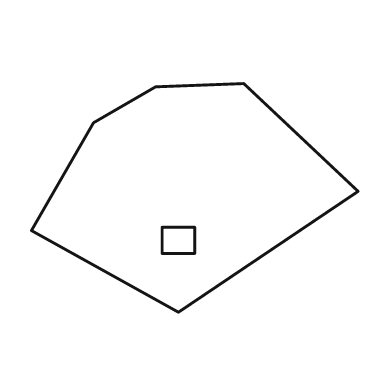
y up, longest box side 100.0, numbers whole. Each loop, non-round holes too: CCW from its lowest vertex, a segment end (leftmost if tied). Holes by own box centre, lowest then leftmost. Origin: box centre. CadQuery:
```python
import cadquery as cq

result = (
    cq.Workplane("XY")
    .moveTo(-5.0, -35.0)
    .lineTo(50.0, 2.0)
    .lineTo(15.0, 35.0)
    .lineTo(-12.0, 34.0)
    .lineTo(-31.0, 23.0)
    .lineTo(-50.0, -10.0)
    .close()
    .moveTo(-10.0, -17.0)
    .lineTo(0.0, -17.0)
    .lineTo(0.0, -9.0)
    .lineTo(-10.0, -9.0)
    .close()
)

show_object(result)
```